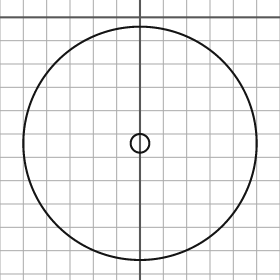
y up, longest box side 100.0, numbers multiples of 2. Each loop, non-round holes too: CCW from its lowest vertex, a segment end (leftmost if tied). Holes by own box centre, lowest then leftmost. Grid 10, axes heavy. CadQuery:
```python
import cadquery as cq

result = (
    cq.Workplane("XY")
    .moveTo(0.0, -54.0)
    .circle(50.0)
    .moveTo(0.0, -54.0)
    .circle(4.0)
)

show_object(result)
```